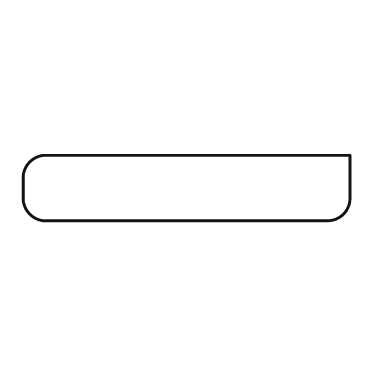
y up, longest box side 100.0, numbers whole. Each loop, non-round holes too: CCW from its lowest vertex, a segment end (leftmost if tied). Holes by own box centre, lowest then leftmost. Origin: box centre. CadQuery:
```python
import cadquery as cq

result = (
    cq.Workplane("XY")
    .moveTo(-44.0, -10.0)
    .lineTo(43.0, -10.0)
    .threePointArc((48.0, -8.0), (50.0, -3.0))
    .lineTo(50.0, 10.0)
    .lineTo(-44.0, 10.0)
    .threePointArc((-48.0, 8.0), (-50.0, 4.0))
    .lineTo(-50.0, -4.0)
    .threePointArc((-48.0, -8.0), (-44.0, -10.0))
    .close()
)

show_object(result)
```